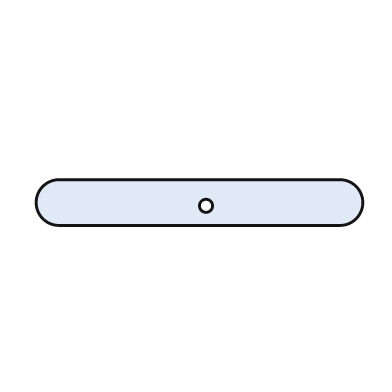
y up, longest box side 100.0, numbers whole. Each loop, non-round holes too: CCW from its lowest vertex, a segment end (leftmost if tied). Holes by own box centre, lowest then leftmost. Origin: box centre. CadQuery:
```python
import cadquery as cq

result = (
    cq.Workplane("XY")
    .moveTo(-43.0, -7.0)
    .lineTo(43.0, -7.0)
    .threePointArc((50.0, 0.0), (43.0, 7.0))
    .lineTo(-43.0, 7.0)
    .threePointArc((-50.0, 0.0), (-43.0, -7.0))
    .close()
    .moveTo(2.0, -1.0)
    .circle(2.0)
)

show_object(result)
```